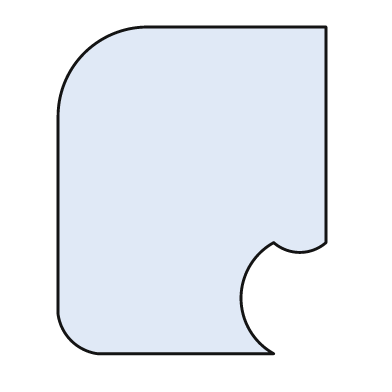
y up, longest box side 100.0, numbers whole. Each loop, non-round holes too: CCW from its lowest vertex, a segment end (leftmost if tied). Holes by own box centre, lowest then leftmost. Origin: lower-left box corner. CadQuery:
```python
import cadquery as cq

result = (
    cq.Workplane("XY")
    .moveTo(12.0, 0.0)
    .lineTo(66.0, 0.0)
    .threePointArc((56.0, 17.0), (66.0, 34.0))
    .threePointArc((74.0, 31.0), (82.0, 34.0))
    .lineTo(82.0, 100.0)
    .lineTo(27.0, 100.0)
    .threePointArc((8.0, 92.0), (0.0, 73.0))
    .lineTo(0.0, 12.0)
    .threePointArc((4.0, 4.0), (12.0, 0.0))
    .close()
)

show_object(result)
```